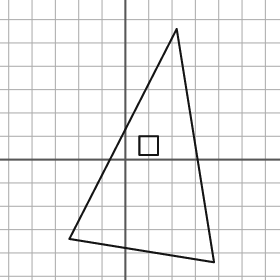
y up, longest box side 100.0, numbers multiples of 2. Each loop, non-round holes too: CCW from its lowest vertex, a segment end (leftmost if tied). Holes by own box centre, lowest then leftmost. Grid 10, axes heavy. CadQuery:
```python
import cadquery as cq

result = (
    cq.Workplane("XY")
    .moveTo(38.0, -44.0)
    .lineTo(22.0, 56.0)
    .lineTo(-24.0, -34.0)
    .close()
    .moveTo(6.0, 2.0)
    .lineTo(14.0, 2.0)
    .lineTo(14.0, 10.0)
    .lineTo(6.0, 10.0)
    .close()
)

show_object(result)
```